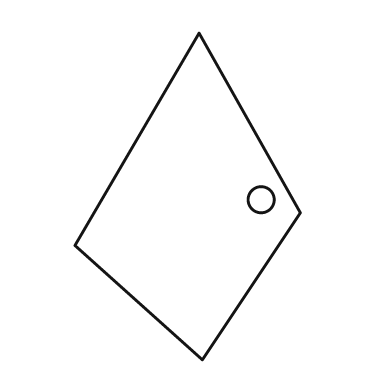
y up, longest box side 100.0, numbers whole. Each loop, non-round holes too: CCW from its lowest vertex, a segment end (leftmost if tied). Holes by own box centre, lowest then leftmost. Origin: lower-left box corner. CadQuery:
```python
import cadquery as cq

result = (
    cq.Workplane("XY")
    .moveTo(39.0, 0.0)
    .lineTo(69.0, 45.0)
    .lineTo(38.0, 100.0)
    .lineTo(0.0, 35.0)
    .close()
    .moveTo(57.0, 49.0)
    .circle(4.0)
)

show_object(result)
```